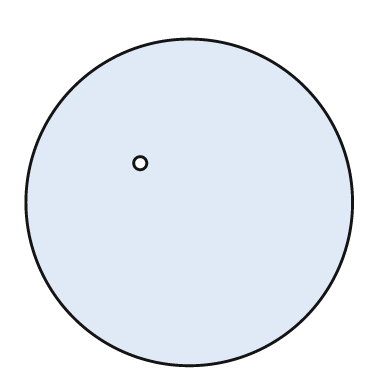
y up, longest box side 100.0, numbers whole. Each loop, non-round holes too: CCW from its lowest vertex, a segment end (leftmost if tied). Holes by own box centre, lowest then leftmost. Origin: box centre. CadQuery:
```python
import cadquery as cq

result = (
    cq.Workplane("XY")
    .moveTo(0.0, 0.0)
    .circle(50.0)
    .moveTo(-15.0, 12.0)
    .circle(2.0)
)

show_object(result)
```